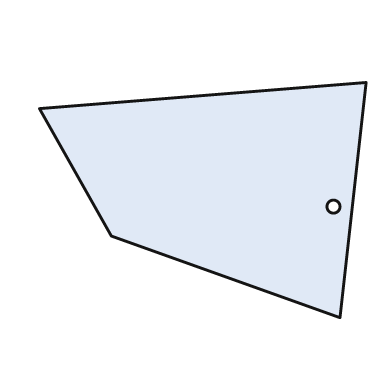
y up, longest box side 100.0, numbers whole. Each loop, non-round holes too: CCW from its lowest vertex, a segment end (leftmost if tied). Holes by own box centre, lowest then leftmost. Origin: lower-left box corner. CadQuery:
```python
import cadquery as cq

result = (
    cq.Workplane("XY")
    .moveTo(92.0, 0.0)
    .lineTo(100.0, 72.0)
    .lineTo(0.0, 64.0)
    .lineTo(22.0, 25.0)
    .close()
    .moveTo(90.0, 34.0)
    .circle(2.0)
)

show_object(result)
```